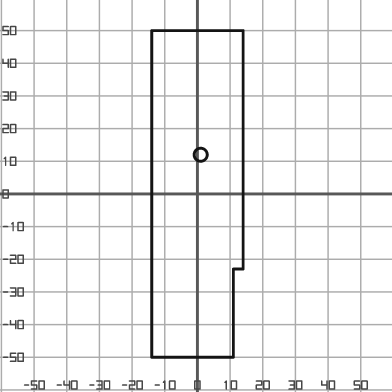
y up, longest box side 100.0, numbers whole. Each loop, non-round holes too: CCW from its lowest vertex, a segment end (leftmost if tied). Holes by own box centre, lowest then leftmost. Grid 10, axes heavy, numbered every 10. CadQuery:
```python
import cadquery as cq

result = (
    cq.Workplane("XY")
    .moveTo(-14.0, -50.0)
    .lineTo(11.0, -50.0)
    .lineTo(11.0, -23.0)
    .lineTo(14.0, -23.0)
    .lineTo(14.0, 50.0)
    .lineTo(-14.0, 50.0)
    .close()
    .moveTo(1.0, 12.0)
    .circle(2.0)
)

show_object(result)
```